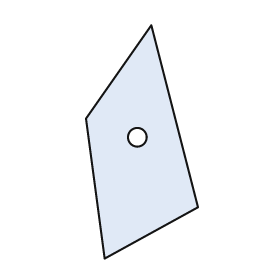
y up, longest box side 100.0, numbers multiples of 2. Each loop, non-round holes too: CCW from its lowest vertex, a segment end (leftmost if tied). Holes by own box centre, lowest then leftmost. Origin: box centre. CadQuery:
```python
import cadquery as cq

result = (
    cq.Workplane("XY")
    .moveTo(-16.0, -50.0)
    .lineTo(24.0, -28.0)
    .lineTo(4.0, 50.0)
    .lineTo(-24.0, 10.0)
    .close()
    .moveTo(-2.0, 2.0)
    .circle(4.0)
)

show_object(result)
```